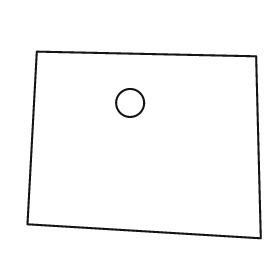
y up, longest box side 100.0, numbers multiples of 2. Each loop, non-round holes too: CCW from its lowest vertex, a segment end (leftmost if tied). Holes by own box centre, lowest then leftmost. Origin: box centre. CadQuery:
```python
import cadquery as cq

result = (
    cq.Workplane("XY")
    .moveTo(50.0, -40.0)
    .lineTo(48.0, 38.0)
    .lineTo(-46.0, 40.0)
    .lineTo(-50.0, -34.0)
    .close()
    .moveTo(-6.0, 18.0)
    .circle(6.0)
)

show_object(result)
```